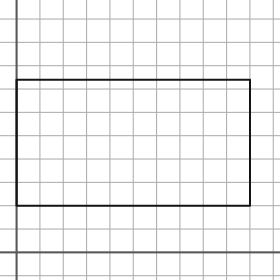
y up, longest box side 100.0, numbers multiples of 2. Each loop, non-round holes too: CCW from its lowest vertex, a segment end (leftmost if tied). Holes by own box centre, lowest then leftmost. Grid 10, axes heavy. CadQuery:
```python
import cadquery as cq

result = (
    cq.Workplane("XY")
    .moveTo(0.0, 20.0)
    .lineTo(100.0, 20.0)
    .lineTo(100.0, 74.0)
    .lineTo(0.0, 74.0)
    .close()
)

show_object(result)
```